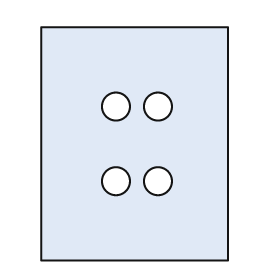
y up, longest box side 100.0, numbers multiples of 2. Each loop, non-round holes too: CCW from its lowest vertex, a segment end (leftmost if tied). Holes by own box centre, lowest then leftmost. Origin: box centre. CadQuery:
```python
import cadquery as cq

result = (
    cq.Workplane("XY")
    .moveTo(-40.0, -50.0)
    .lineTo(40.0, -50.0)
    .lineTo(40.0, 50.0)
    .lineTo(-40.0, 50.0)
    .close()
    .moveTo(-8.0, -16.0)
    .circle(6.0)
    .moveTo(10.0, -16.0)
    .circle(6.0)
    .moveTo(-8.0, 16.0)
    .circle(6.0)
    .moveTo(10.0, 16.0)
    .circle(6.0)
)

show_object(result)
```